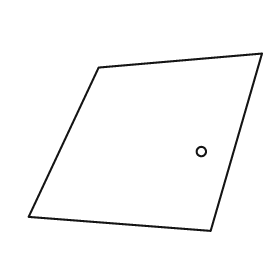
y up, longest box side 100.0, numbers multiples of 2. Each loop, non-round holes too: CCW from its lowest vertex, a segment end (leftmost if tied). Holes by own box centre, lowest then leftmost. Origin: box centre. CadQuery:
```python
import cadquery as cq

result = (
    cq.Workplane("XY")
    .moveTo(28.0, -38.0)
    .lineTo(50.0, 38.0)
    .lineTo(-20.0, 32.0)
    .lineTo(-50.0, -32.0)
    .close()
    .moveTo(24.0, -4.0)
    .circle(2.0)
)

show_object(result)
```